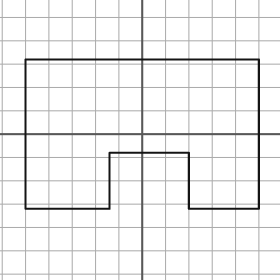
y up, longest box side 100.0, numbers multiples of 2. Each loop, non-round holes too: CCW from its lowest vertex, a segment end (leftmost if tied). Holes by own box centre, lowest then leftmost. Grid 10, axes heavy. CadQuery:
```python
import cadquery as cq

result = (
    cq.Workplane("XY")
    .moveTo(-50.0, -32.0)
    .lineTo(-14.0, -32.0)
    .lineTo(-14.0, -8.0)
    .lineTo(20.0, -8.0)
    .lineTo(20.0, -32.0)
    .lineTo(50.0, -32.0)
    .lineTo(50.0, 32.0)
    .lineTo(-50.0, 32.0)
    .close()
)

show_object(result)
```